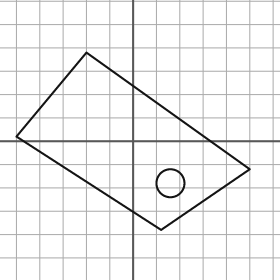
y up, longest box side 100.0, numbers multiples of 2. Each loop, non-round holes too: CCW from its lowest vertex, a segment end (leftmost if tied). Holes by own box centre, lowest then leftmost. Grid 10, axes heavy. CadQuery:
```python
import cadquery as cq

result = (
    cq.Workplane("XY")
    .moveTo(12.0, -38.0)
    .lineTo(50.0, -12.0)
    .lineTo(-20.0, 38.0)
    .lineTo(-50.0, 2.0)
    .close()
    .moveTo(16.0, -18.0)
    .circle(6.0)
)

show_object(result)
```